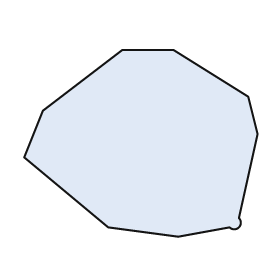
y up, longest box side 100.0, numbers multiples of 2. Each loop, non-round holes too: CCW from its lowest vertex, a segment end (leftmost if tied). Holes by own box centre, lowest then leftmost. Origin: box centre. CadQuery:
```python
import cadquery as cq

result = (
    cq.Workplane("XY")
    .moveTo(16.0, -40.0)
    .lineTo(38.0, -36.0)
    .threePointArc((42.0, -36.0), (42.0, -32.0))
    .lineTo(50.0, 4.0)
    .lineTo(46.0, 20.0)
    .lineTo(14.0, 40.0)
    .lineTo(-8.0, 40.0)
    .lineTo(-42.0, 14.0)
    .lineTo(-50.0, -6.0)
    .lineTo(-14.0, -36.0)
    .close()
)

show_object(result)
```